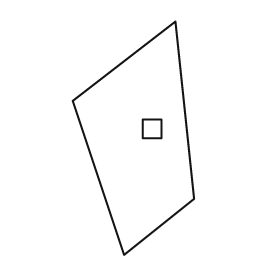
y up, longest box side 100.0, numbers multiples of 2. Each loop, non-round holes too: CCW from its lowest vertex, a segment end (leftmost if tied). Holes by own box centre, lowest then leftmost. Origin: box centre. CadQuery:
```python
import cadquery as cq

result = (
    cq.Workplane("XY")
    .moveTo(-4.0, -50.0)
    .lineTo(26.0, -26.0)
    .lineTo(18.0, 50.0)
    .lineTo(-26.0, 16.0)
    .close()
    .moveTo(4.0, 0.0)
    .lineTo(12.0, 0.0)
    .lineTo(12.0, 8.0)
    .lineTo(4.0, 8.0)
    .close()
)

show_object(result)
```